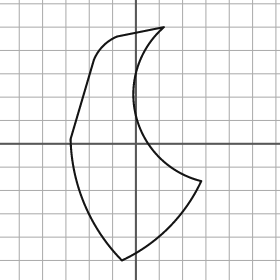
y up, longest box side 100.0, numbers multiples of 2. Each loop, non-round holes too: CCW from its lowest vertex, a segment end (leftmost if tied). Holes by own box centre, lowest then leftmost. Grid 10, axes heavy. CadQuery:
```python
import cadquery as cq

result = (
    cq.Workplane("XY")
    .moveTo(-6.0, -50.0)
    .threePointArc((14.0, -36.0), (28.0, -16.0))
    .threePointArc((0.0, 12.0), (12.0, 50.0))
    .lineTo(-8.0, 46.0)
    .threePointArc((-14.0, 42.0), (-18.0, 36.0))
    .lineTo(-28.0, 2.0)
    .threePointArc((-22.0, -26.0), (-6.0, -50.0))
    .close()
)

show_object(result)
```